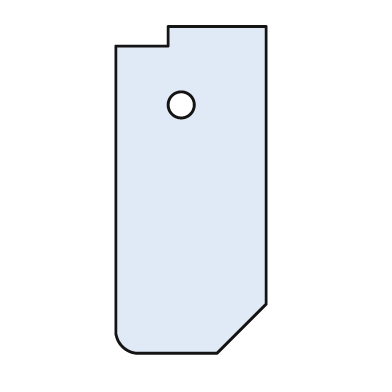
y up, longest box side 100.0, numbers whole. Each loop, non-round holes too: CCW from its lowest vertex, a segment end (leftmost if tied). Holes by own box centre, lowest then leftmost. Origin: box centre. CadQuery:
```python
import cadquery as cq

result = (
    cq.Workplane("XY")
    .moveTo(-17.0, -50.0)
    .lineTo(8.0, -50.0)
    .lineTo(23.0, -35.0)
    .lineTo(23.0, 50.0)
    .lineTo(-7.0, 50.0)
    .lineTo(-7.0, 44.0)
    .lineTo(-23.0, 44.0)
    .lineTo(-23.0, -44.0)
    .threePointArc((-21.0, -48.0), (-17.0, -50.0))
    .close()
    .moveTo(-3.0, 26.0)
    .circle(4.0)
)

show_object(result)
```